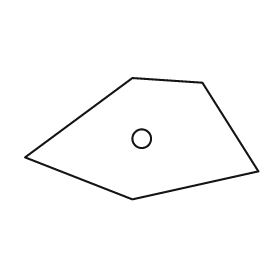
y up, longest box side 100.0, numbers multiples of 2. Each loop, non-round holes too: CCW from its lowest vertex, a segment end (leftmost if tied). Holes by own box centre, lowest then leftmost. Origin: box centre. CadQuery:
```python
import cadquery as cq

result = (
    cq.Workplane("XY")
    .moveTo(-4.0, -26.0)
    .lineTo(50.0, -14.0)
    .lineTo(26.0, 24.0)
    .lineTo(-4.0, 26.0)
    .lineTo(-50.0, -8.0)
    .close()
    .moveTo(0.0, 0.0)
    .circle(4.0)
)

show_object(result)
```